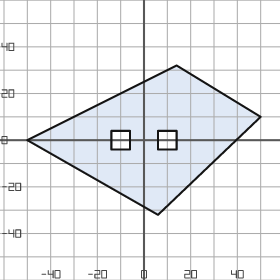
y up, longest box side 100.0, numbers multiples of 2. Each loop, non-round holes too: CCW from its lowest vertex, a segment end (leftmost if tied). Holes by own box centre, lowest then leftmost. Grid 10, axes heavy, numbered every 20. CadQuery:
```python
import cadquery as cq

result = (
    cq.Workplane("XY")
    .moveTo(6.0, -32.0)
    .lineTo(50.0, 10.0)
    .lineTo(14.0, 32.0)
    .lineTo(-50.0, 0.0)
    .close()
    .moveTo(-14.0, -4.0)
    .lineTo(-6.0, -4.0)
    .lineTo(-6.0, 4.0)
    .lineTo(-14.0, 4.0)
    .close()
    .moveTo(6.0, -4.0)
    .lineTo(14.0, -4.0)
    .lineTo(14.0, 4.0)
    .lineTo(6.0, 4.0)
    .close()
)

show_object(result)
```